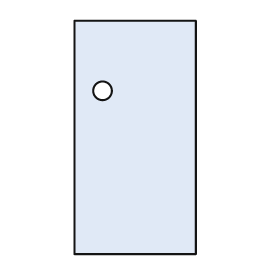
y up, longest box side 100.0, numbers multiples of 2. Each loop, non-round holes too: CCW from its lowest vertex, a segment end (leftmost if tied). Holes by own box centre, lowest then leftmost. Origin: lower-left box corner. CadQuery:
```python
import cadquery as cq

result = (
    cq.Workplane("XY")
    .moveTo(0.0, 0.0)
    .lineTo(52.0, 0.0)
    .lineTo(52.0, 100.0)
    .lineTo(0.0, 100.0)
    .close()
    .moveTo(12.0, 70.0)
    .circle(4.0)
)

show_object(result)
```